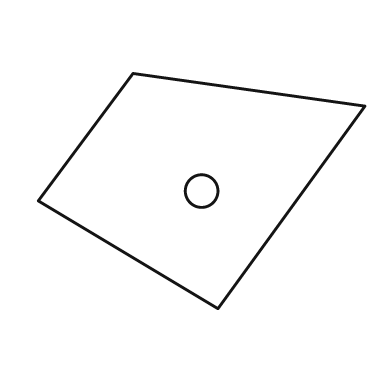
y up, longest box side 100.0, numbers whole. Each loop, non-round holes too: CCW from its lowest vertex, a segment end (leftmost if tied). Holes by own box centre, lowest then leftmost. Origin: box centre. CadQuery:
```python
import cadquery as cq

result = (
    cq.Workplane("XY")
    .moveTo(5.0, -36.0)
    .lineTo(50.0, 26.0)
    .lineTo(-21.0, 36.0)
    .lineTo(-50.0, -3.0)
    .close()
    .moveTo(0.0, 0.0)
    .circle(5.0)
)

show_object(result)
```